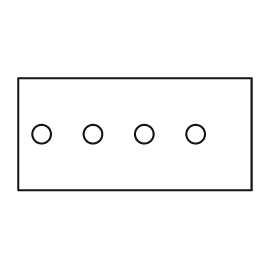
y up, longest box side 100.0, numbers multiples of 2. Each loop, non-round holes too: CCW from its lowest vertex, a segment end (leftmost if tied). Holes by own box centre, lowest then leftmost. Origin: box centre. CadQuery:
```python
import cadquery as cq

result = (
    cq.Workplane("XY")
    .moveTo(-50.0, -24.0)
    .lineTo(50.0, -24.0)
    .lineTo(50.0, 24.0)
    .lineTo(-50.0, 24.0)
    .close()
    .moveTo(-40.0, 0.0)
    .circle(4.0)
    .moveTo(-18.0, 0.0)
    .circle(4.0)
    .moveTo(4.0, 0.0)
    .circle(4.0)
    .moveTo(26.0, 0.0)
    .circle(4.0)
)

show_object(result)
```